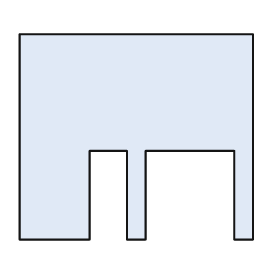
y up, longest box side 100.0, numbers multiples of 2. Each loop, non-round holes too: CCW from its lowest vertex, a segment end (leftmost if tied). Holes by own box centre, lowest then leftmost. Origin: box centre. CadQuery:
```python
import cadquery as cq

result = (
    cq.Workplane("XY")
    .moveTo(-50.0, -44.0)
    .lineTo(-20.0, -44.0)
    .lineTo(-20.0, -6.0)
    .lineTo(-4.0, -6.0)
    .lineTo(-4.0, -44.0)
    .lineTo(4.0, -44.0)
    .lineTo(4.0, -6.0)
    .lineTo(42.0, -6.0)
    .lineTo(42.0, -44.0)
    .lineTo(50.0, -44.0)
    .lineTo(50.0, 44.0)
    .lineTo(-50.0, 44.0)
    .close()
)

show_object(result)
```